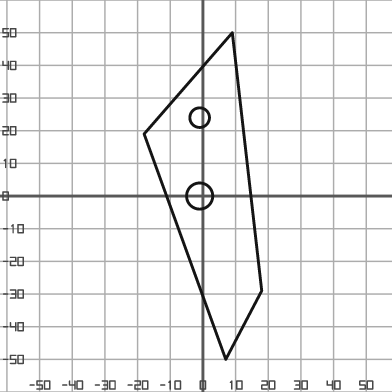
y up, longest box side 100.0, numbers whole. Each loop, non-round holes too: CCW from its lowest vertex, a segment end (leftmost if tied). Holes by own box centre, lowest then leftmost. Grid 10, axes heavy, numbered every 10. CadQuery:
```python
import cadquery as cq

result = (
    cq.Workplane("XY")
    .moveTo(7.0, -50.0)
    .lineTo(18.0, -29.0)
    .lineTo(9.0, 50.0)
    .lineTo(-18.0, 19.0)
    .close()
    .moveTo(-1.0, 0.0)
    .circle(4.0)
    .moveTo(-1.0, 24.0)
    .circle(3.0)
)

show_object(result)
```